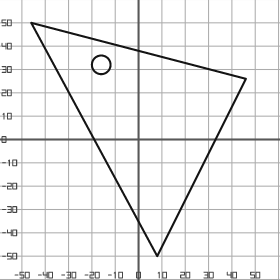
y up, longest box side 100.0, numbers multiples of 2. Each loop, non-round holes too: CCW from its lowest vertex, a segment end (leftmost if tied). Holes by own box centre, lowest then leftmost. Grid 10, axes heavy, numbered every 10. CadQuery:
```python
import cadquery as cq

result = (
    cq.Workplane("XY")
    .moveTo(8.0, -50.0)
    .lineTo(46.0, 26.0)
    .lineTo(-46.0, 50.0)
    .close()
    .moveTo(-16.0, 32.0)
    .circle(4.0)
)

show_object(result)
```